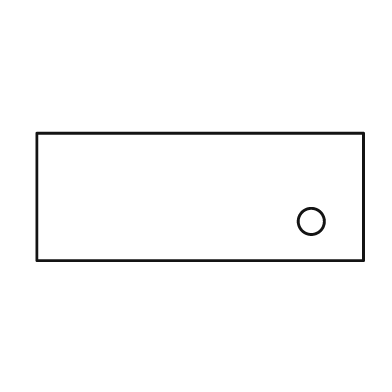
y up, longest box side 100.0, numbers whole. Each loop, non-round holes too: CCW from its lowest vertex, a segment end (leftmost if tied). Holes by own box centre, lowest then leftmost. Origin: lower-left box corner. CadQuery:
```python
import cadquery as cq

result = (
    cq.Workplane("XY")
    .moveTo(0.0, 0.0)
    .lineTo(100.0, 0.0)
    .lineTo(100.0, 39.0)
    .lineTo(0.0, 39.0)
    .close()
    .moveTo(84.0, 12.0)
    .circle(4.0)
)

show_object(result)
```